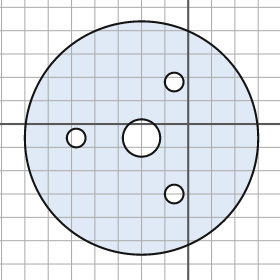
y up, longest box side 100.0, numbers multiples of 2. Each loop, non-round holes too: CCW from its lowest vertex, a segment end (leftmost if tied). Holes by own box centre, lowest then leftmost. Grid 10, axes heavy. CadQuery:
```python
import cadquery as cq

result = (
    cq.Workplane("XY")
    .moveTo(-20.0, -6.0)
    .circle(50.0)
    .moveTo(-6.0, -30.0)
    .circle(4.0)
    .moveTo(-48.0, -6.0)
    .circle(4.0)
    .moveTo(-20.0, -6.0)
    .circle(8.0)
    .moveTo(-6.0, 18.0)
    .circle(4.0)
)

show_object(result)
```